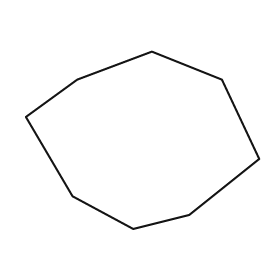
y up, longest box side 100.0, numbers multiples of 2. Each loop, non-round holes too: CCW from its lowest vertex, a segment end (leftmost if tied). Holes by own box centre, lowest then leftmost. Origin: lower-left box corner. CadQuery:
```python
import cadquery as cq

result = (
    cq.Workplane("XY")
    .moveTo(46.0, 0.0)
    .lineTo(70.0, 6.0)
    .lineTo(100.0, 30.0)
    .lineTo(84.0, 64.0)
    .lineTo(54.0, 76.0)
    .lineTo(22.0, 64.0)
    .lineTo(0.0, 48.0)
    .lineTo(20.0, 14.0)
    .close()
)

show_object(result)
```